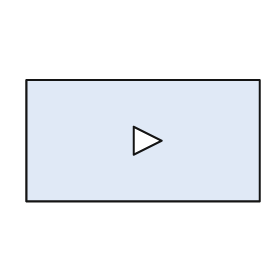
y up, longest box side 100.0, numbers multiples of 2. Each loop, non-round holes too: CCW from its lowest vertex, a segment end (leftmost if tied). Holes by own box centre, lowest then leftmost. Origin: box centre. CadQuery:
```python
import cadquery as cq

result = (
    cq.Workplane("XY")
    .moveTo(-50.0, -26.0)
    .lineTo(50.0, -26.0)
    .lineTo(50.0, 26.0)
    .lineTo(-50.0, 26.0)
    .close()
    .moveTo(-4.0, -6.0)
    .lineTo(8.0, 0.0)
    .lineTo(-4.0, 6.0)
    .close()
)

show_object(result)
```